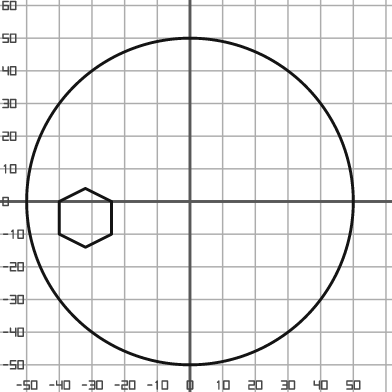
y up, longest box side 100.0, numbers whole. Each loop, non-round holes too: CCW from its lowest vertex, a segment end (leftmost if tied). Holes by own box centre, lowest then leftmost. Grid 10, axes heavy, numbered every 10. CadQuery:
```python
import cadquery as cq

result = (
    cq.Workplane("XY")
    .moveTo(0.0, 0.0)
    .circle(50.0)
    .moveTo(-32.0, -14.0)
    .lineTo(-24.0, -10.0)
    .lineTo(-24.0, 0.0)
    .lineTo(-32.0, 4.0)
    .lineTo(-40.0, 0.0)
    .lineTo(-40.0, -10.0)
    .close()
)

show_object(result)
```